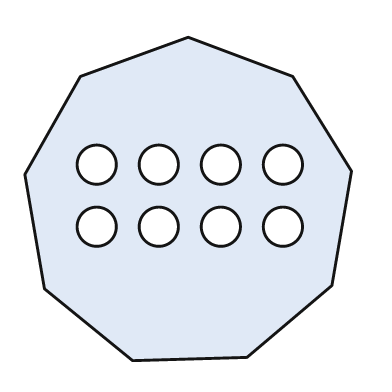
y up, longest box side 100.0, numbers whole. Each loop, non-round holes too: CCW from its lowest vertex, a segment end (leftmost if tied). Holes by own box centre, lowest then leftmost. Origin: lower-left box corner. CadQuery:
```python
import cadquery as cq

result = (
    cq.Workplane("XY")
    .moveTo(33.0, 0.0)
    .lineTo(68.0, 1.0)
    .lineTo(94.0, 23.0)
    .lineTo(100.0, 58.0)
    .lineTo(82.0, 87.0)
    .lineTo(50.0, 99.0)
    .lineTo(17.0, 87.0)
    .lineTo(0.0, 57.0)
    .lineTo(6.0, 22.0)
    .close()
    .moveTo(22.0, 41.0)
    .circle(6.0)
    .moveTo(41.0, 41.0)
    .circle(6.0)
    .moveTo(60.0, 41.0)
    .circle(6.0)
    .moveTo(79.0, 41.0)
    .circle(6.0)
    .moveTo(22.0, 60.0)
    .circle(6.0)
    .moveTo(41.0, 60.0)
    .circle(6.0)
    .moveTo(60.0, 60.0)
    .circle(6.0)
    .moveTo(79.0, 60.0)
    .circle(6.0)
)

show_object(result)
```